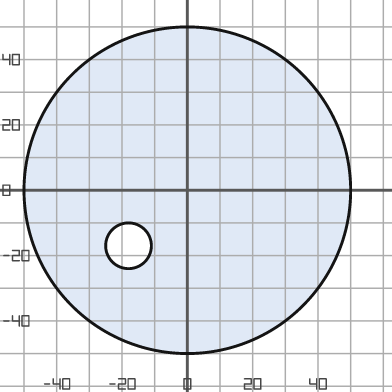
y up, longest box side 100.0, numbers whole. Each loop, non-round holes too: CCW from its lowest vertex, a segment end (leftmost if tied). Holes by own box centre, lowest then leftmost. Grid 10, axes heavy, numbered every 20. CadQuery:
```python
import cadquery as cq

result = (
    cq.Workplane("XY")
    .moveTo(0.0, 0.0)
    .circle(50.0)
    .moveTo(-18.0, -17.0)
    .circle(7.0)
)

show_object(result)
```